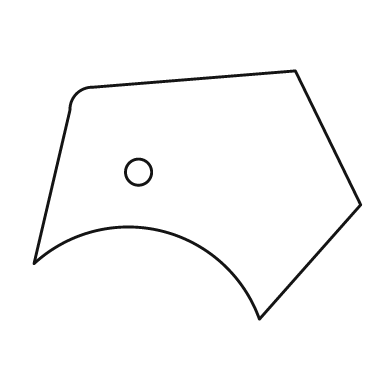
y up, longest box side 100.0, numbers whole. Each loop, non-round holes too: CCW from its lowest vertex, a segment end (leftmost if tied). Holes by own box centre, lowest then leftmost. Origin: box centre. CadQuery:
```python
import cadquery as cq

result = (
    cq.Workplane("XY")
    .moveTo(19.0, -38.0)
    .lineTo(50.0, -3.0)
    .lineTo(30.0, 38.0)
    .lineTo(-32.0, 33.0)
    .threePointArc((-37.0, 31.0), (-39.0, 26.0))
    .lineTo(-50.0, -21.0)
    .threePointArc((-11.0, -11.0), (19.0, -38.0))
    .close()
    .moveTo(-18.0, 7.0)
    .circle(4.0)
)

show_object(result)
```